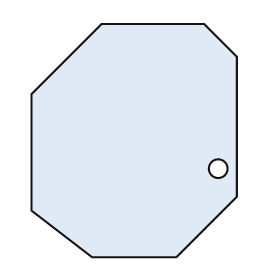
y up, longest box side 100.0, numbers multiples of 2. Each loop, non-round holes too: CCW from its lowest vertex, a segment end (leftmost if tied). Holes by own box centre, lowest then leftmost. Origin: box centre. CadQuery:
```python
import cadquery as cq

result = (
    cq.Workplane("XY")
    .moveTo(-18.0, -50.0)
    .lineTo(18.0, -50.0)
    .lineTo(44.0, -24.0)
    .lineTo(44.0, 36.0)
    .lineTo(30.0, 50.0)
    .lineTo(-14.0, 50.0)
    .lineTo(-44.0, 20.0)
    .lineTo(-44.0, -30.0)
    .close()
    .moveTo(36.0, -12.0)
    .circle(4.0)
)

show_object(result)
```